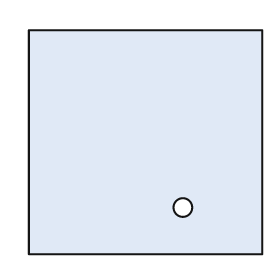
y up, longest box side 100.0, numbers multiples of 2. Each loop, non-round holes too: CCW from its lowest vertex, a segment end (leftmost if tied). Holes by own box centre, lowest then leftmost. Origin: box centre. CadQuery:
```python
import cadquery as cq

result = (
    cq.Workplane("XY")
    .moveTo(-50.0, -48.0)
    .lineTo(50.0, -48.0)
    .lineTo(50.0, 48.0)
    .lineTo(-50.0, 48.0)
    .close()
    .moveTo(16.0, -28.0)
    .circle(4.0)
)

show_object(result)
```